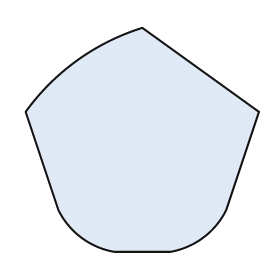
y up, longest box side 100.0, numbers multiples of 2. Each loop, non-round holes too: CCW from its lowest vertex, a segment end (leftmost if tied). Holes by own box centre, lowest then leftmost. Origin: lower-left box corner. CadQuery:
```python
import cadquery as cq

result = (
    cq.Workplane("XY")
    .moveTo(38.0, 0.0)
    .lineTo(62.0, 0.0)
    .threePointArc((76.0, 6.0), (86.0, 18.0))
    .lineTo(100.0, 60.0)
    .lineTo(50.0, 96.0)
    .threePointArc((22.0, 82.0), (0.0, 60.0))
    .lineTo(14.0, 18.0)
    .threePointArc((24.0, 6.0), (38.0, 0.0))
    .close()
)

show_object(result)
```